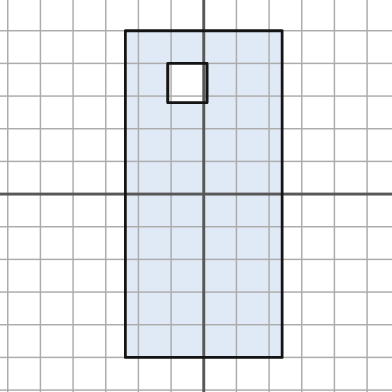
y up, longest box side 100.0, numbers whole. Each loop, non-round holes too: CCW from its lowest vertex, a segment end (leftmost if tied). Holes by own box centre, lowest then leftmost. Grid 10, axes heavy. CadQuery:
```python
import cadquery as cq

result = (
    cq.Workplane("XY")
    .moveTo(-24.0, -50.0)
    .lineTo(24.0, -50.0)
    .lineTo(24.0, 50.0)
    .lineTo(-24.0, 50.0)
    .close()
    .moveTo(-11.0, 28.0)
    .lineTo(1.0, 28.0)
    .lineTo(1.0, 40.0)
    .lineTo(-11.0, 40.0)
    .close()
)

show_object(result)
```